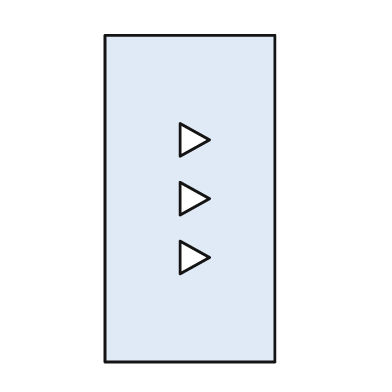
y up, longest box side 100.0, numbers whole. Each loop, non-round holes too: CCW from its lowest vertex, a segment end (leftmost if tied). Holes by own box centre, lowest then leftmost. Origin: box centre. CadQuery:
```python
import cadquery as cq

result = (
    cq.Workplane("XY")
    .moveTo(-26.0, -50.0)
    .lineTo(26.0, -50.0)
    .lineTo(26.0, 50.0)
    .lineTo(-26.0, 50.0)
    .close()
    .moveTo(-3.0, -23.0)
    .lineTo(6.0, -18.0)
    .lineTo(-3.0, -13.0)
    .close()
    .moveTo(-3.0, -5.0)
    .lineTo(6.0, 0.0)
    .lineTo(-3.0, 5.0)
    .close()
    .moveTo(-3.0, 13.0)
    .lineTo(6.0, 18.0)
    .lineTo(-3.0, 23.0)
    .close()
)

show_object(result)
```